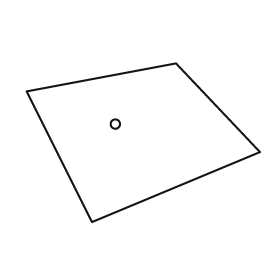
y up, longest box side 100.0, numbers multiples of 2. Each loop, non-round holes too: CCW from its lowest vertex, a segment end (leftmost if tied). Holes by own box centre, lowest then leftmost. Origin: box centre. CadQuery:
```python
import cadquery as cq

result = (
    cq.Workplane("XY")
    .moveTo(-22.0, -34.0)
    .lineTo(50.0, -4.0)
    .lineTo(14.0, 34.0)
    .lineTo(-50.0, 22.0)
    .close()
    .moveTo(-12.0, 8.0)
    .circle(2.0)
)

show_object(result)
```